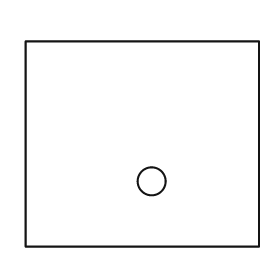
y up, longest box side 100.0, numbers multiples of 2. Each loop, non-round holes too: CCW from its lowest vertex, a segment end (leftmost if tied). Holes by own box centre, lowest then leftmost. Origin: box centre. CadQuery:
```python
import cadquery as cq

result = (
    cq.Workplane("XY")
    .moveTo(-50.0, -44.0)
    .lineTo(50.0, -44.0)
    .lineTo(50.0, 44.0)
    .lineTo(-50.0, 44.0)
    .close()
    .moveTo(4.0, -16.0)
    .circle(6.0)
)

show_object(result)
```